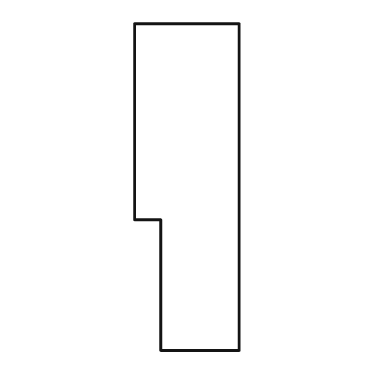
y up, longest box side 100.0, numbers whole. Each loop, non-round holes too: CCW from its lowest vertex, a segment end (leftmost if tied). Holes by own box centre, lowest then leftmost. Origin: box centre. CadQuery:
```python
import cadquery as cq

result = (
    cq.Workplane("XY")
    .moveTo(-8.0, -50.0)
    .lineTo(16.0, -50.0)
    .lineTo(16.0, 50.0)
    .lineTo(-16.0, 50.0)
    .lineTo(-16.0, -10.0)
    .lineTo(-8.0, -10.0)
    .close()
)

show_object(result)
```